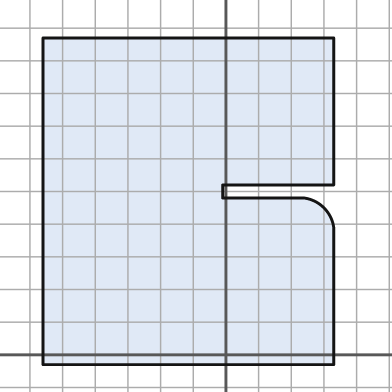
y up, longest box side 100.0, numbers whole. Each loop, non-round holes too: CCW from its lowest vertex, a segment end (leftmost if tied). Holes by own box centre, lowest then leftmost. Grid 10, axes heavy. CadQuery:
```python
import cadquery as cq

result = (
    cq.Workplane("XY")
    .moveTo(-56.0, -3.0)
    .lineTo(33.0, -3.0)
    .lineTo(33.0, 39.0)
    .threePointArc((30.0, 45.0), (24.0, 48.0))
    .lineTo(-1.0, 48.0)
    .lineTo(-1.0, 52.0)
    .lineTo(33.0, 52.0)
    .lineTo(33.0, 97.0)
    .lineTo(-56.0, 97.0)
    .close()
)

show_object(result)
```